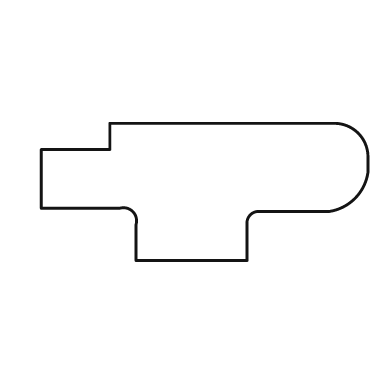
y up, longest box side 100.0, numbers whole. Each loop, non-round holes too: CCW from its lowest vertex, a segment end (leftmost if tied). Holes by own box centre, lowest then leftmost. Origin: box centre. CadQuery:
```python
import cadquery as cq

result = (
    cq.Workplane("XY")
    .moveTo(-21.0, -21.0)
    .lineTo(13.0, -21.0)
    .lineTo(13.0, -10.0)
    .threePointArc((14.0, -7.0), (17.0, -6.0))
    .lineTo(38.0, -6.0)
    .threePointArc((46.0, -2.0), (50.0, 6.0))
    .lineTo(50.0, 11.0)
    .threePointArc((47.0, 18.0), (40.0, 21.0))
    .lineTo(-29.0, 21.0)
    .lineTo(-29.0, 13.0)
    .lineTo(-50.0, 13.0)
    .lineTo(-50.0, -5.0)
    .lineTo(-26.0, -5.0)
    .threePointArc((-22.0, -6.0), (-21.0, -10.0))
    .close()
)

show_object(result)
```